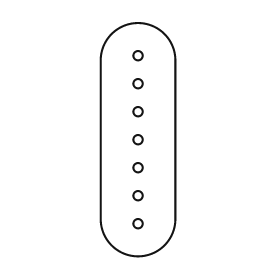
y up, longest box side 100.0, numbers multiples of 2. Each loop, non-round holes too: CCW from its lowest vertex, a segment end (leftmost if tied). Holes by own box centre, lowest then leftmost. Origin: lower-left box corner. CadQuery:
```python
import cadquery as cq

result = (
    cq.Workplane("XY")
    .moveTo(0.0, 16.0)
    .threePointArc((16.0, 0.0), (32.0, 16.0))
    .lineTo(32.0, 84.0)
    .threePointArc((16.0, 100.0), (0.0, 84.0))
    .close()
    .moveTo(16.0, 14.0)
    .circle(2.0)
    .moveTo(16.0, 26.0)
    .circle(2.0)
    .moveTo(16.0, 38.0)
    .circle(2.0)
    .moveTo(16.0, 50.0)
    .circle(2.0)
    .moveTo(16.0, 62.0)
    .circle(2.0)
    .moveTo(16.0, 74.0)
    .circle(2.0)
    .moveTo(16.0, 86.0)
    .circle(2.0)
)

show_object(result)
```